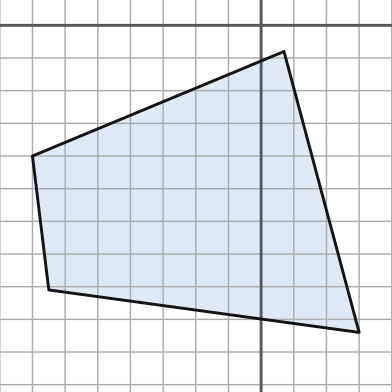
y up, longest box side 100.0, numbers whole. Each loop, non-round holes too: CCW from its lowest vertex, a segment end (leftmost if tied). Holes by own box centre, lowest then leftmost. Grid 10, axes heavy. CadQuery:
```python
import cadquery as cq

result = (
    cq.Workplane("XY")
    .moveTo(30.0, -94.0)
    .lineTo(7.0, -8.0)
    .lineTo(-70.0, -40.0)
    .lineTo(-65.0, -81.0)
    .close()
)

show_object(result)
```